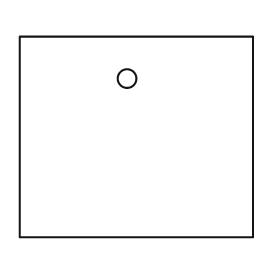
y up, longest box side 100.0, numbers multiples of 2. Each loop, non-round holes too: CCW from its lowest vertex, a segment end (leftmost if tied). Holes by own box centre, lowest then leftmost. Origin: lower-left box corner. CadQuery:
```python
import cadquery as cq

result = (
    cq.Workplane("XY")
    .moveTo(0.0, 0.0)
    .lineTo(100.0, 0.0)
    .lineTo(100.0, 86.0)
    .lineTo(0.0, 86.0)
    .close()
    .moveTo(46.0, 68.0)
    .circle(4.0)
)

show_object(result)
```